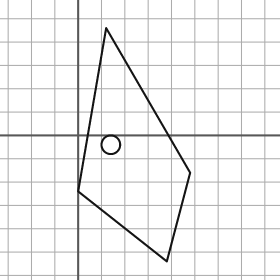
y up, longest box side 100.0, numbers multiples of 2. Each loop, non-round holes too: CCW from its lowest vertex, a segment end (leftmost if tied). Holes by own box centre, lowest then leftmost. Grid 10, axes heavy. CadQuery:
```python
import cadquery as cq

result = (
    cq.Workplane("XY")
    .moveTo(38.0, -54.0)
    .lineTo(48.0, -16.0)
    .lineTo(12.0, 46.0)
    .lineTo(0.0, -24.0)
    .close()
    .moveTo(14.0, -4.0)
    .circle(4.0)
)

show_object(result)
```